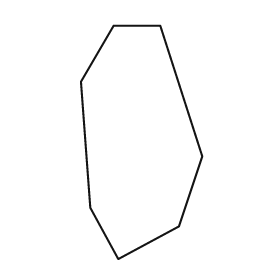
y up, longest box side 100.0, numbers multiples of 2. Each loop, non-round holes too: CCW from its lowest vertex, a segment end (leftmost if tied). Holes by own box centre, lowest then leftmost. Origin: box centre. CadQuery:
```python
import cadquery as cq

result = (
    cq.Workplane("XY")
    .moveTo(-10.0, -50.0)
    .lineTo(16.0, -36.0)
    .lineTo(26.0, -6.0)
    .lineTo(8.0, 50.0)
    .lineTo(-12.0, 50.0)
    .lineTo(-26.0, 26.0)
    .lineTo(-22.0, -28.0)
    .close()
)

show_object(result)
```